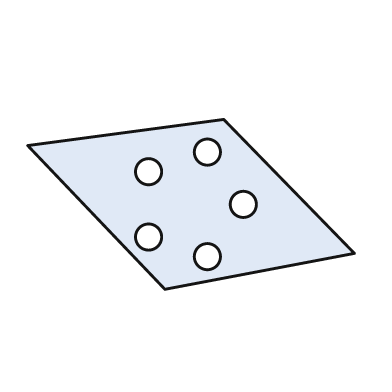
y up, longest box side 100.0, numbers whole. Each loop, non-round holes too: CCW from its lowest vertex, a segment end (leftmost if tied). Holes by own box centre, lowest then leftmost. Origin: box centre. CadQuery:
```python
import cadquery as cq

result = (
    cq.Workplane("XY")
    .moveTo(-8.0, -26.0)
    .lineTo(50.0, -15.0)
    .lineTo(10.0, 26.0)
    .lineTo(-50.0, 18.0)
    .close()
    .moveTo(5.0, -16.0)
    .circle(4.0)
    .moveTo(-13.0, -10.0)
    .circle(4.0)
    .moveTo(16.0, 0.0)
    .circle(4.0)
    .moveTo(-13.0, 10.0)
    .circle(4.0)
    .moveTo(5.0, 16.0)
    .circle(4.0)
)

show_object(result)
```